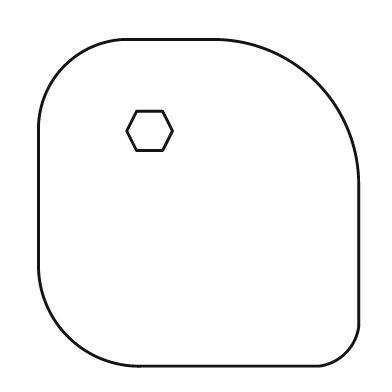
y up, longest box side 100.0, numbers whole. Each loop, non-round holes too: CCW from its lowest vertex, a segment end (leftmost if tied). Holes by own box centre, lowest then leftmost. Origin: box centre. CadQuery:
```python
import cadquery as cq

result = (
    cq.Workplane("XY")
    .moveTo(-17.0, -50.0)
    .lineTo(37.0, -50.0)
    .threePointArc((45.0, -46.0), (49.0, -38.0))
    .lineTo(49.0, 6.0)
    .threePointArc((36.0, 37.0), (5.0, 50.0))
    .lineTo(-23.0, 50.0)
    .threePointArc((-41.0, 42.0), (-49.0, 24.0))
    .lineTo(-49.0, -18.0)
    .threePointArc((-40.0, -41.0), (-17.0, -50.0))
    .close()
    .moveTo(-19.0, 16.0)
    .lineTo(-11.0, 16.0)
    .lineTo(-8.0, 22.0)
    .lineTo(-11.0, 28.0)
    .lineTo(-19.0, 28.0)
    .lineTo(-22.0, 22.0)
    .close()
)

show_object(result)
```